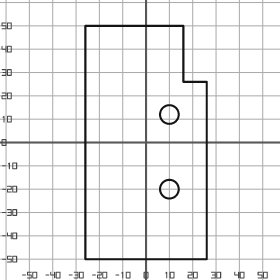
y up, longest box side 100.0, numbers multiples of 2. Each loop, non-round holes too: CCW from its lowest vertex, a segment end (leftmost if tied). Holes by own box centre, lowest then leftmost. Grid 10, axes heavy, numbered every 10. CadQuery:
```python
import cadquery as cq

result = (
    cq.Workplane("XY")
    .moveTo(-26.0, -50.0)
    .lineTo(26.0, -50.0)
    .lineTo(26.0, 26.0)
    .lineTo(16.0, 26.0)
    .lineTo(16.0, 50.0)
    .lineTo(-26.0, 50.0)
    .close()
    .moveTo(10.0, -20.0)
    .circle(4.0)
    .moveTo(10.0, 12.0)
    .circle(4.0)
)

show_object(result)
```